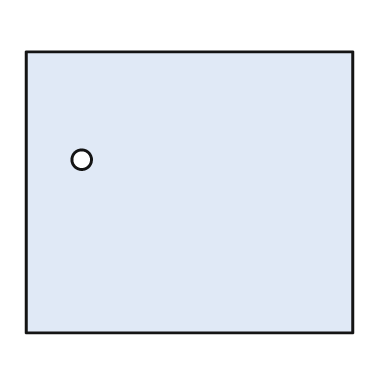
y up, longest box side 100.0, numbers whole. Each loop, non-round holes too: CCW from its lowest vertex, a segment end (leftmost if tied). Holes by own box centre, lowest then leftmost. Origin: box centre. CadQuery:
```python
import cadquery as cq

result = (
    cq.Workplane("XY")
    .moveTo(-50.0, -43.0)
    .lineTo(50.0, -43.0)
    .lineTo(50.0, 43.0)
    .lineTo(-50.0, 43.0)
    .close()
    .moveTo(-33.0, 10.0)
    .circle(3.0)
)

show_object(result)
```